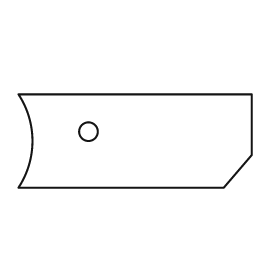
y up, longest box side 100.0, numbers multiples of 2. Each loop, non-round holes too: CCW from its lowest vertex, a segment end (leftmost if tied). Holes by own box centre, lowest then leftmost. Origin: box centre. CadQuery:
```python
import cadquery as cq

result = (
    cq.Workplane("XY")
    .moveTo(-50.0, -20.0)
    .lineTo(38.0, -20.0)
    .lineTo(50.0, -6.0)
    .lineTo(50.0, 20.0)
    .lineTo(-50.0, 20.0)
    .threePointArc((-44.0, 0.0), (-50.0, -20.0))
    .close()
    .moveTo(-20.0, 4.0)
    .circle(4.0)
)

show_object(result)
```